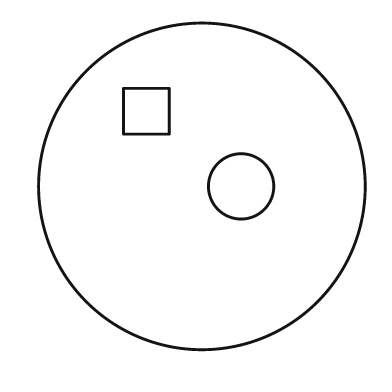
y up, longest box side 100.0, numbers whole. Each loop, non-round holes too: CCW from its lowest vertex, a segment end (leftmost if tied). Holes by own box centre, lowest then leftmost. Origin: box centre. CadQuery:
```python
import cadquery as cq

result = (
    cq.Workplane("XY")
    .moveTo(0.0, 0.0)
    .circle(50.0)
    .moveTo(12.0, 0.0)
    .circle(10.0)
    .moveTo(-24.0, 16.0)
    .lineTo(-10.0, 16.0)
    .lineTo(-10.0, 30.0)
    .lineTo(-24.0, 30.0)
    .close()
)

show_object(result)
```